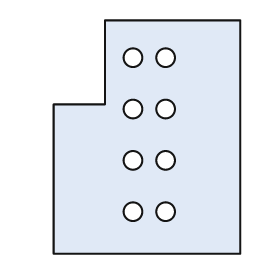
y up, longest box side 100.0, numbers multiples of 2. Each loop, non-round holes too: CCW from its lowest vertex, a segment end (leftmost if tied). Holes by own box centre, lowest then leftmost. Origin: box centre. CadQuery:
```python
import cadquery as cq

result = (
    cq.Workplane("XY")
    .moveTo(-40.0, -50.0)
    .lineTo(40.0, -50.0)
    .lineTo(40.0, 50.0)
    .lineTo(-18.0, 50.0)
    .lineTo(-18.0, 14.0)
    .lineTo(-40.0, 14.0)
    .close()
    .moveTo(-6.0, -32.0)
    .circle(4.0)
    .moveTo(8.0, -32.0)
    .circle(4.0)
    .moveTo(-6.0, -10.0)
    .circle(4.0)
    .moveTo(8.0, -10.0)
    .circle(4.0)
    .moveTo(-6.0, 12.0)
    .circle(4.0)
    .moveTo(8.0, 12.0)
    .circle(4.0)
    .moveTo(-6.0, 34.0)
    .circle(4.0)
    .moveTo(8.0, 34.0)
    .circle(4.0)
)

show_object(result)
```